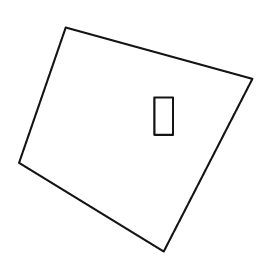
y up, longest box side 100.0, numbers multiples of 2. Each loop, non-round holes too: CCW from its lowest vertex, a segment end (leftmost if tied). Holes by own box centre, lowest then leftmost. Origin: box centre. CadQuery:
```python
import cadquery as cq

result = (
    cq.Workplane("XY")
    .moveTo(12.0, -48.0)
    .lineTo(50.0, 26.0)
    .lineTo(-30.0, 48.0)
    .lineTo(-50.0, -10.0)
    .close()
    .moveTo(8.0, 2.0)
    .lineTo(16.0, 2.0)
    .lineTo(16.0, 18.0)
    .lineTo(8.0, 18.0)
    .close()
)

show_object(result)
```